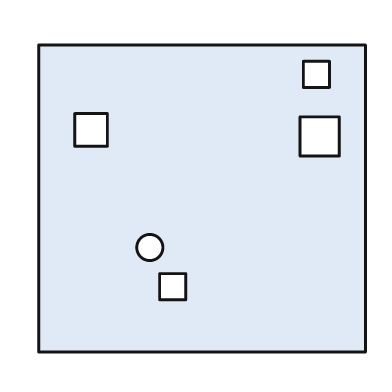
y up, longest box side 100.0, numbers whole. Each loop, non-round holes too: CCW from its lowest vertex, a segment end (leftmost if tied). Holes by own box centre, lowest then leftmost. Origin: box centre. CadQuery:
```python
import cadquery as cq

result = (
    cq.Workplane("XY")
    .moveTo(-50.0, -47.0)
    .lineTo(50.0, -47.0)
    .lineTo(50.0, 47.0)
    .lineTo(-50.0, 47.0)
    .close()
    .moveTo(-13.0, -31.0)
    .lineTo(-5.0, -31.0)
    .lineTo(-5.0, -23.0)
    .lineTo(-13.0, -23.0)
    .close()
    .moveTo(-16.0, -15.0)
    .circle(4.0)
    .moveTo(30.0, 13.0)
    .lineTo(42.0, 13.0)
    .lineTo(42.0, 25.0)
    .lineTo(30.0, 25.0)
    .close()
    .moveTo(-39.0, 16.0)
    .lineTo(-29.0, 16.0)
    .lineTo(-29.0, 26.0)
    .lineTo(-39.0, 26.0)
    .close()
    .moveTo(31.0, 34.0)
    .lineTo(39.0, 34.0)
    .lineTo(39.0, 42.0)
    .lineTo(31.0, 42.0)
    .close()
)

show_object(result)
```